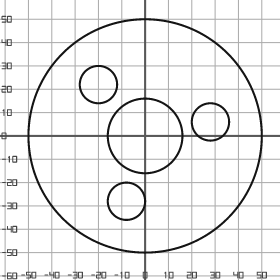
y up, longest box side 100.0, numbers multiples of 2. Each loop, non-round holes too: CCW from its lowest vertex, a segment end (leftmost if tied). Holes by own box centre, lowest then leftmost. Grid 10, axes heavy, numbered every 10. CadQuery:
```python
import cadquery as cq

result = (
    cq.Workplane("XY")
    .moveTo(0.0, 0.0)
    .circle(50.0)
    .moveTo(-8.0, -28.0)
    .circle(8.0)
    .moveTo(0.0, 0.0)
    .circle(16.0)
    .moveTo(28.0, 6.0)
    .circle(8.0)
    .moveTo(-20.0, 22.0)
    .circle(8.0)
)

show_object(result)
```